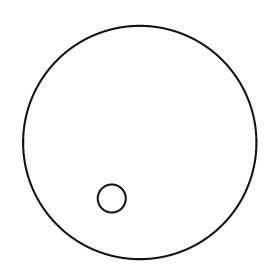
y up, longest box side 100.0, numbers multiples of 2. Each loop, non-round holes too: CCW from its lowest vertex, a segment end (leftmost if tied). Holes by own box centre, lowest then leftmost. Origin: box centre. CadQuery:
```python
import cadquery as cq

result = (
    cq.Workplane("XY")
    .moveTo(0.0, 0.0)
    .circle(50.0)
    .moveTo(-12.0, -24.0)
    .circle(6.0)
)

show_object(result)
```